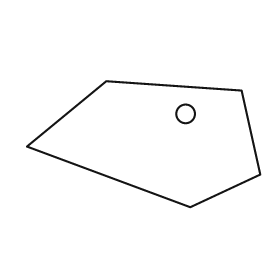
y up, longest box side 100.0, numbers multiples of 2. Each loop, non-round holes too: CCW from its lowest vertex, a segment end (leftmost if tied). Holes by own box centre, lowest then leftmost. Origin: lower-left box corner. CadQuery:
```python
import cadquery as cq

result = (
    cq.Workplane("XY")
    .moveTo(70.0, 0.0)
    .lineTo(100.0, 14.0)
    .lineTo(92.0, 50.0)
    .lineTo(34.0, 54.0)
    .lineTo(0.0, 26.0)
    .close()
    .moveTo(68.0, 40.0)
    .circle(4.0)
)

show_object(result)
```